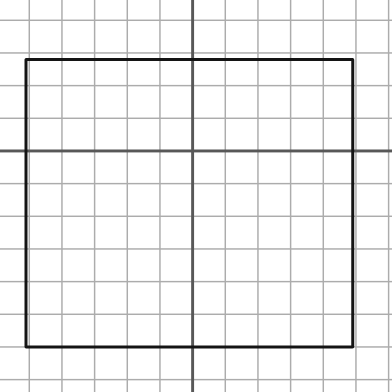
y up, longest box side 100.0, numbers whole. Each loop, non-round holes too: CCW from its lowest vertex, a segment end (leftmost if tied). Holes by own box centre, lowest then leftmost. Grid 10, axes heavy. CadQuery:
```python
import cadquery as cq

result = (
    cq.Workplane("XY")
    .moveTo(-51.0, -60.0)
    .lineTo(49.0, -60.0)
    .lineTo(49.0, 28.0)
    .lineTo(-51.0, 28.0)
    .close()
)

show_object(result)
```